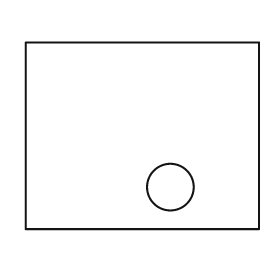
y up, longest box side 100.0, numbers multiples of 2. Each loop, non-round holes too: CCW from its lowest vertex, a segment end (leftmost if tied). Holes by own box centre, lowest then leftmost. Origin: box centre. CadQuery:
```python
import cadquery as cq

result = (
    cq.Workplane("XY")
    .moveTo(-50.0, -40.0)
    .lineTo(50.0, -40.0)
    .lineTo(50.0, 40.0)
    .lineTo(-50.0, 40.0)
    .close()
    .moveTo(12.0, -22.0)
    .circle(10.0)
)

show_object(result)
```